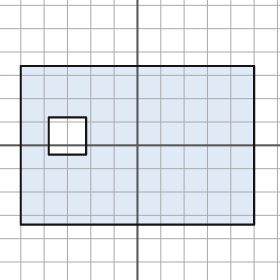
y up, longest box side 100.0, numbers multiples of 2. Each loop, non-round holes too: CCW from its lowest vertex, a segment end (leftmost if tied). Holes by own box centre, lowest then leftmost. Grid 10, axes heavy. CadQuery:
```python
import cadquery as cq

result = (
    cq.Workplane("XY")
    .moveTo(-50.0, -34.0)
    .lineTo(50.0, -34.0)
    .lineTo(50.0, 34.0)
    .lineTo(-50.0, 34.0)
    .close()
    .moveTo(-38.0, -4.0)
    .lineTo(-22.0, -4.0)
    .lineTo(-22.0, 12.0)
    .lineTo(-38.0, 12.0)
    .close()
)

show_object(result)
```